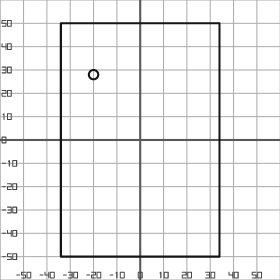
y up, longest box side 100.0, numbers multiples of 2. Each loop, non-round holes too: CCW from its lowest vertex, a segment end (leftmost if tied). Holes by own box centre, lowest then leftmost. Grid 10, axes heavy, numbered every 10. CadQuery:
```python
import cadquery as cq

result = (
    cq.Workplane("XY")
    .moveTo(-34.0, -50.0)
    .lineTo(34.0, -50.0)
    .lineTo(34.0, 50.0)
    .lineTo(-34.0, 50.0)
    .close()
    .moveTo(-20.0, 28.0)
    .circle(2.0)
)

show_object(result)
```